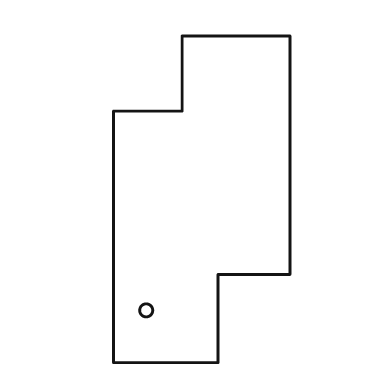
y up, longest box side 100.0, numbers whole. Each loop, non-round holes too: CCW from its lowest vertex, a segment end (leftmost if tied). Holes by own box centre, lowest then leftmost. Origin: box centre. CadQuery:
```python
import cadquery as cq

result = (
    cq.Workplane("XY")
    .moveTo(-27.0, -50.0)
    .lineTo(5.0, -50.0)
    .lineTo(5.0, -23.0)
    .lineTo(27.0, -23.0)
    .lineTo(27.0, 50.0)
    .lineTo(-6.0, 50.0)
    .lineTo(-6.0, 27.0)
    .lineTo(-27.0, 27.0)
    .close()
    .moveTo(-17.0, -34.0)
    .circle(2.0)
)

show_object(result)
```